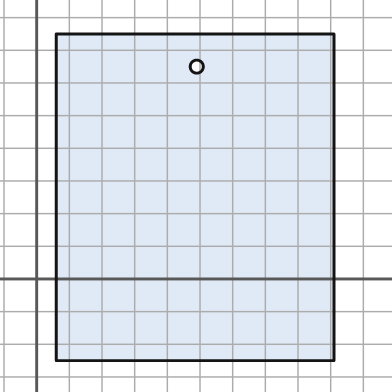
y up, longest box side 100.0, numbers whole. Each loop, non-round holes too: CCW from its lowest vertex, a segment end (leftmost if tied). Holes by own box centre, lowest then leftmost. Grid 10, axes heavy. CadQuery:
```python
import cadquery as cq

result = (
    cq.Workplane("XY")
    .moveTo(6.0, -25.0)
    .lineTo(91.0, -25.0)
    .lineTo(91.0, 75.0)
    .lineTo(6.0, 75.0)
    .close()
    .moveTo(49.0, 65.0)
    .circle(2.0)
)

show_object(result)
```